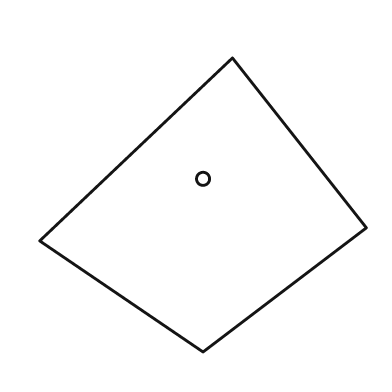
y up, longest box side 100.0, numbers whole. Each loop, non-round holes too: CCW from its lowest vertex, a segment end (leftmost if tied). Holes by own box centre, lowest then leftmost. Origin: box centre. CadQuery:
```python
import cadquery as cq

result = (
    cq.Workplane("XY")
    .moveTo(0.0, -45.0)
    .lineTo(50.0, -7.0)
    .lineTo(9.0, 45.0)
    .lineTo(-50.0, -11.0)
    .close()
    .moveTo(0.0, 8.0)
    .circle(2.0)
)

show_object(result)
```